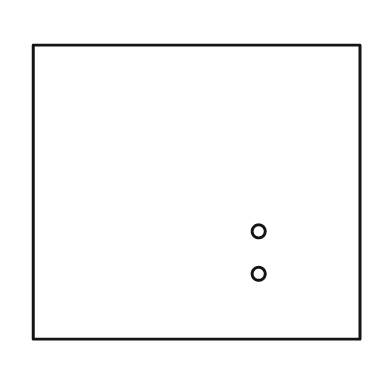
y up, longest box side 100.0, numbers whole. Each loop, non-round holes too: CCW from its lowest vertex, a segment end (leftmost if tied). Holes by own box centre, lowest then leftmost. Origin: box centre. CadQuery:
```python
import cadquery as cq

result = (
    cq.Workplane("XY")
    .moveTo(-50.0, -45.0)
    .lineTo(50.0, -45.0)
    .lineTo(50.0, 45.0)
    .lineTo(-50.0, 45.0)
    .close()
    .moveTo(19.0, -25.0)
    .circle(2.0)
    .moveTo(19.0, -12.0)
    .circle(2.0)
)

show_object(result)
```